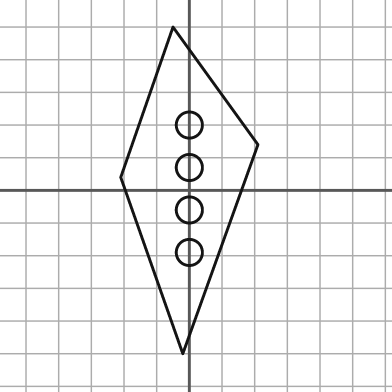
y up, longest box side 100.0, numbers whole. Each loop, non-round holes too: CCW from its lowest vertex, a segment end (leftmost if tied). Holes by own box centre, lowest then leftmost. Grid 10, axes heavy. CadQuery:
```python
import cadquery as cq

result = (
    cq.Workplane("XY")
    .moveTo(-2.0, -50.0)
    .lineTo(21.0, 14.0)
    .lineTo(-5.0, 50.0)
    .lineTo(-21.0, 4.0)
    .close()
    .moveTo(0.0, -19.0)
    .circle(4.0)
    .moveTo(0.0, -6.0)
    .circle(4.0)
    .moveTo(0.0, 7.0)
    .circle(4.0)
    .moveTo(0.0, 20.0)
    .circle(4.0)
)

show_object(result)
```